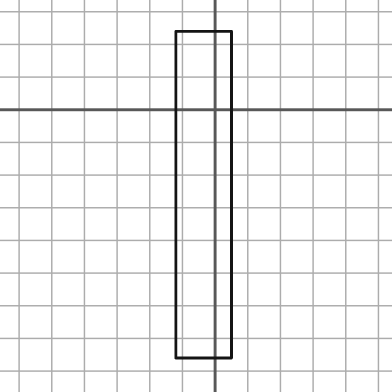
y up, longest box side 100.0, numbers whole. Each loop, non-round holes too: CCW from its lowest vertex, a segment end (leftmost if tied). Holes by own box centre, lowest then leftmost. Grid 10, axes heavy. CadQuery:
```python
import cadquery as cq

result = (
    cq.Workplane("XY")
    .moveTo(-12.0, -76.0)
    .lineTo(5.0, -76.0)
    .lineTo(5.0, 24.0)
    .lineTo(-12.0, 24.0)
    .close()
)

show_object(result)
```